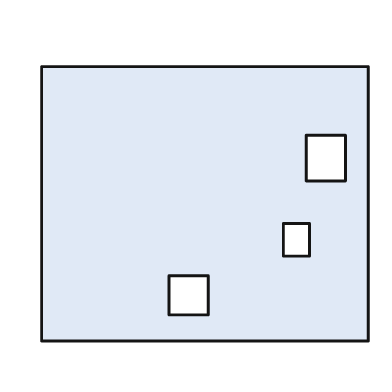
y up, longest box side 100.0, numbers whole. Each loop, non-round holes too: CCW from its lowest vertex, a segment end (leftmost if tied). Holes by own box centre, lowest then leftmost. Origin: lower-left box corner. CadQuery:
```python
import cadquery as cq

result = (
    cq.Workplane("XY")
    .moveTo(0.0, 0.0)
    .lineTo(100.0, 0.0)
    .lineTo(100.0, 84.0)
    .lineTo(0.0, 84.0)
    .close()
    .moveTo(39.0, 8.0)
    .lineTo(51.0, 8.0)
    .lineTo(51.0, 20.0)
    .lineTo(39.0, 20.0)
    .close()
    .moveTo(74.0, 26.0)
    .lineTo(82.0, 26.0)
    .lineTo(82.0, 36.0)
    .lineTo(74.0, 36.0)
    .close()
    .moveTo(81.0, 49.0)
    .lineTo(93.0, 49.0)
    .lineTo(93.0, 63.0)
    .lineTo(81.0, 63.0)
    .close()
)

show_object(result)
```